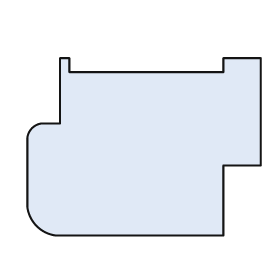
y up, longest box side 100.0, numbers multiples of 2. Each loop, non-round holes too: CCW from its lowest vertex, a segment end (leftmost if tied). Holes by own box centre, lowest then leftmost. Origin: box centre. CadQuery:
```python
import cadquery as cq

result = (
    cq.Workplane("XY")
    .moveTo(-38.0, -38.0)
    .lineTo(34.0, -38.0)
    .lineTo(34.0, -8.0)
    .lineTo(50.0, -8.0)
    .lineTo(50.0, 38.0)
    .lineTo(34.0, 38.0)
    .lineTo(34.0, 32.0)
    .lineTo(-32.0, 32.0)
    .lineTo(-32.0, 38.0)
    .lineTo(-36.0, 38.0)
    .lineTo(-36.0, 10.0)
    .lineTo(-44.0, 10.0)
    .threePointArc((-48.0, 8.0), (-50.0, 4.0))
    .lineTo(-50.0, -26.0)
    .threePointArc((-46.0, -34.0), (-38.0, -38.0))
    .close()
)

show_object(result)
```